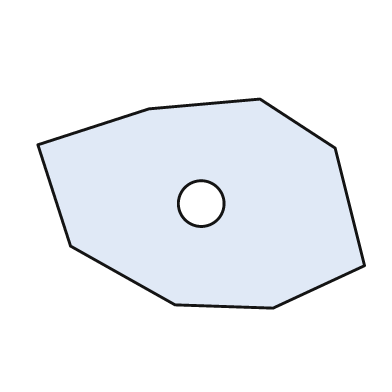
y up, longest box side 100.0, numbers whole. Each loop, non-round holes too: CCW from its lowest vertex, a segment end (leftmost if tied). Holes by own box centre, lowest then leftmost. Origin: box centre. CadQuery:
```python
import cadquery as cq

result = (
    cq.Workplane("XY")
    .moveTo(22.0, -32.0)
    .lineTo(50.0, -19.0)
    .lineTo(41.0, 17.0)
    .lineTo(18.0, 32.0)
    .lineTo(-16.0, 29.0)
    .lineTo(-50.0, 18.0)
    .lineTo(-40.0, -13.0)
    .lineTo(-8.0, -31.0)
    .close()
    .moveTo(0.0, 0.0)
    .circle(7.0)
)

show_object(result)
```